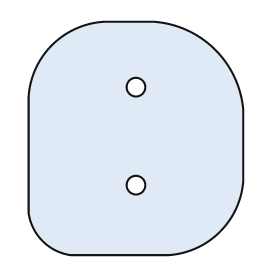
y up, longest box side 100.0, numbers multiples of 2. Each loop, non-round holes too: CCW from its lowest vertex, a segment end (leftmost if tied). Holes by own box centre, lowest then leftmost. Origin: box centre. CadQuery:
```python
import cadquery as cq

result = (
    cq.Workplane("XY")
    .moveTo(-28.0, -50.0)
    .lineTo(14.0, -50.0)
    .threePointArc((36.0, -40.0), (46.0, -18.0))
    .lineTo(46.0, 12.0)
    .threePointArc((34.0, 38.0), (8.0, 50.0))
    .lineTo(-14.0, 50.0)
    .threePointArc((-36.0, 40.0), (-46.0, 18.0))
    .lineTo(-46.0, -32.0)
    .threePointArc((-40.0, -44.0), (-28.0, -50.0))
    .close()
    .moveTo(0.0, -20.0)
    .circle(4.0)
    .moveTo(0.0, 22.0)
    .circle(4.0)
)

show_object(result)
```